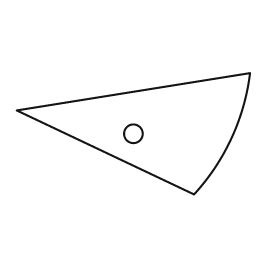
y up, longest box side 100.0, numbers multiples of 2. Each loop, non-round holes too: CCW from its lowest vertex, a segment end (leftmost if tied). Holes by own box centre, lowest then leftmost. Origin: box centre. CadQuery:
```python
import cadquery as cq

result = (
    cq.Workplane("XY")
    .moveTo(26.0, -26.0)
    .threePointArc((42.0, -2.0), (50.0, 26.0))
    .lineTo(-50.0, 10.0)
    .close()
    .moveTo(0.0, 0.0)
    .circle(4.0)
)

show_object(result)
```